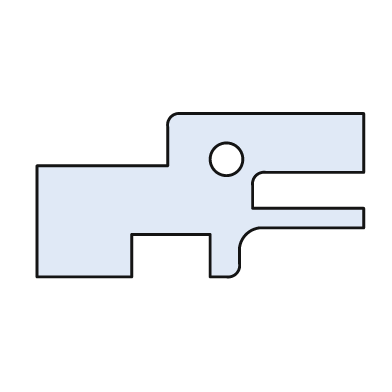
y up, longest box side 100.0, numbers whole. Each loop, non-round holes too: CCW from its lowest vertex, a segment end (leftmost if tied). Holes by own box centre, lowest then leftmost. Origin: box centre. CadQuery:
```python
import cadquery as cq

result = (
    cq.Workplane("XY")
    .moveTo(-50.0, -25.0)
    .lineTo(-21.0, -25.0)
    .lineTo(-21.0, -12.0)
    .lineTo(3.0, -12.0)
    .lineTo(3.0, -25.0)
    .lineTo(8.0, -25.0)
    .threePointArc((11.0, -24.0), (12.0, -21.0))
    .lineTo(12.0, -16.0)
    .threePointArc((14.0, -12.0), (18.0, -10.0))
    .lineTo(50.0, -10.0)
    .lineTo(50.0, -4.0)
    .lineTo(16.0, -4.0)
    .lineTo(16.0, 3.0)
    .threePointArc((17.0, 6.0), (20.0, 7.0))
    .lineTo(50.0, 7.0)
    .lineTo(50.0, 25.0)
    .lineTo(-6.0, 25.0)
    .threePointArc((-9.0, 24.0), (-10.0, 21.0))
    .lineTo(-10.0, 9.0)
    .lineTo(-50.0, 9.0)
    .close()
    .moveTo(8.0, 11.0)
    .circle(5.0)
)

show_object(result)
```